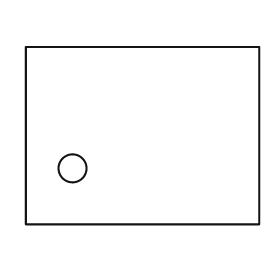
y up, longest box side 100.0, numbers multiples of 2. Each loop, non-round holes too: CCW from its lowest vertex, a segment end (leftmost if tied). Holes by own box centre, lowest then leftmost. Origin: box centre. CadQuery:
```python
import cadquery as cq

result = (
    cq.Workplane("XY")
    .moveTo(-50.0, -38.0)
    .lineTo(50.0, -38.0)
    .lineTo(50.0, 38.0)
    .lineTo(-50.0, 38.0)
    .close()
    .moveTo(-30.0, -14.0)
    .circle(6.0)
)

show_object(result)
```